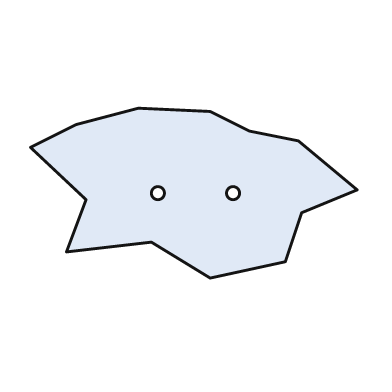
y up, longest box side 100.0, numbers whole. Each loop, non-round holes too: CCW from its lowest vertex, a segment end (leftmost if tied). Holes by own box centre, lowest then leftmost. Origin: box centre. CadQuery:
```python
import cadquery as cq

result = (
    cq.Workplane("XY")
    .moveTo(5.0, -26.0)
    .lineTo(28.0, -21.0)
    .lineTo(33.0, -6.0)
    .lineTo(50.0, 1.0)
    .lineTo(32.0, 16.0)
    .lineTo(17.0, 19.0)
    .lineTo(5.0, 25.0)
    .lineTo(-17.0, 26.0)
    .lineTo(-36.0, 21.0)
    .lineTo(-50.0, 14.0)
    .lineTo(-33.0, -2.0)
    .lineTo(-39.0, -18.0)
    .lineTo(-13.0, -15.0)
    .close()
    .moveTo(-11.0, 0.0)
    .circle(2.0)
    .moveTo(12.0, 0.0)
    .circle(2.0)
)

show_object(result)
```